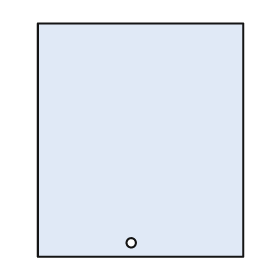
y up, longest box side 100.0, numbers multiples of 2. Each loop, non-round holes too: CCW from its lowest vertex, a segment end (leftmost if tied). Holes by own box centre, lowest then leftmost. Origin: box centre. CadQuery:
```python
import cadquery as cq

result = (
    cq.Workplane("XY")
    .moveTo(-44.0, -50.0)
    .lineTo(44.0, -50.0)
    .lineTo(44.0, 50.0)
    .lineTo(-44.0, 50.0)
    .close()
    .moveTo(-4.0, -44.0)
    .circle(2.0)
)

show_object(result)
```